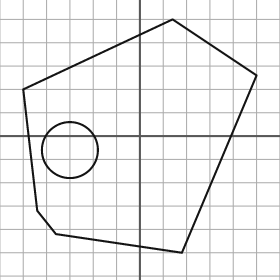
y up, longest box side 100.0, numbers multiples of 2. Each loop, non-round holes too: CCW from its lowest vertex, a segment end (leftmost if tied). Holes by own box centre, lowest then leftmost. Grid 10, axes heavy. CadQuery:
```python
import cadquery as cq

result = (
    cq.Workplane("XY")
    .moveTo(18.0, -50.0)
    .lineTo(50.0, 26.0)
    .lineTo(14.0, 50.0)
    .lineTo(-50.0, 20.0)
    .lineTo(-44.0, -32.0)
    .lineTo(-36.0, -42.0)
    .close()
    .moveTo(-30.0, -6.0)
    .circle(12.0)
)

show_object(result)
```